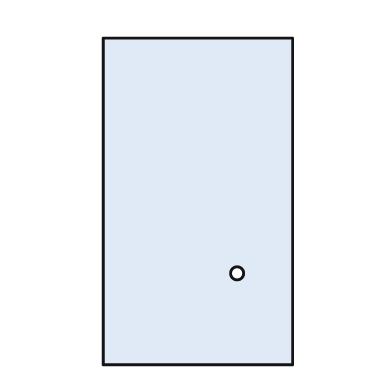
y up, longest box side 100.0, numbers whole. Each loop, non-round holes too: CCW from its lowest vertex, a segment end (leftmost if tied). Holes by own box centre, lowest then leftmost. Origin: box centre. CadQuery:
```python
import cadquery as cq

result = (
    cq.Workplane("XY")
    .moveTo(-29.0, -50.0)
    .lineTo(29.0, -50.0)
    .lineTo(29.0, 50.0)
    .lineTo(-29.0, 50.0)
    .close()
    .moveTo(12.0, -22.0)
    .circle(2.0)
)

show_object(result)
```